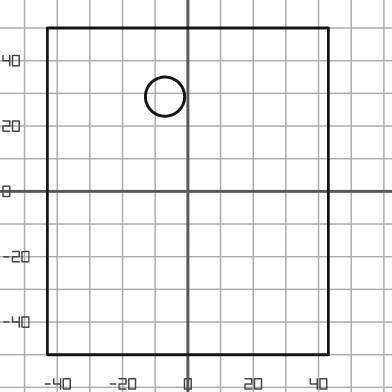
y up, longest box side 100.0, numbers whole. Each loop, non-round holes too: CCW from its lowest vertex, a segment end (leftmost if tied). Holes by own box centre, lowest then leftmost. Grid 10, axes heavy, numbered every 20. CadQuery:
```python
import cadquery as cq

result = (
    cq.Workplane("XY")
    .moveTo(-43.0, -50.0)
    .lineTo(43.0, -50.0)
    .lineTo(43.0, 50.0)
    .lineTo(-43.0, 50.0)
    .close()
    .moveTo(-7.0, 29.0)
    .circle(6.0)
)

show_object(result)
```